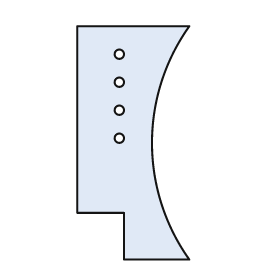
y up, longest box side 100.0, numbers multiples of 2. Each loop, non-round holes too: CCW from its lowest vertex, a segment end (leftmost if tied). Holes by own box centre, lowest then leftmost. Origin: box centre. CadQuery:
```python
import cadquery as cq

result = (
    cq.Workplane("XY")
    .moveTo(-4.0, -50.0)
    .lineTo(24.0, -50.0)
    .threePointArc((8.0, 0.0), (24.0, 50.0))
    .lineTo(-24.0, 50.0)
    .lineTo(-24.0, -30.0)
    .lineTo(-4.0, -30.0)
    .close()
    .moveTo(-6.0, 2.0)
    .circle(2.0)
    .moveTo(-6.0, 14.0)
    .circle(2.0)
    .moveTo(-6.0, 26.0)
    .circle(2.0)
    .moveTo(-6.0, 38.0)
    .circle(2.0)
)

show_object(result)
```